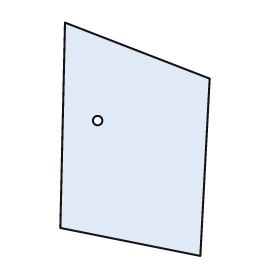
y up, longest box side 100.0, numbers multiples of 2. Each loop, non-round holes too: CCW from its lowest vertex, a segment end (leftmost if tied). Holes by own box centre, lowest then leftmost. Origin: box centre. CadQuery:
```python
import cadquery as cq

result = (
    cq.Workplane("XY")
    .moveTo(28.0, -50.0)
    .lineTo(32.0, 26.0)
    .lineTo(-30.0, 50.0)
    .lineTo(-32.0, -38.0)
    .close()
    .moveTo(-16.0, 8.0)
    .circle(2.0)
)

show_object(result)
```